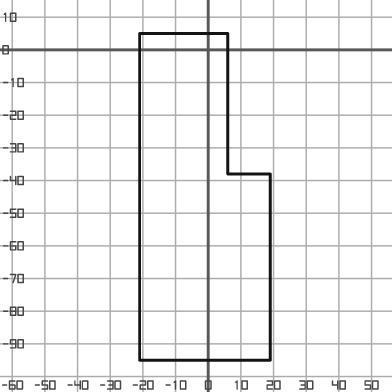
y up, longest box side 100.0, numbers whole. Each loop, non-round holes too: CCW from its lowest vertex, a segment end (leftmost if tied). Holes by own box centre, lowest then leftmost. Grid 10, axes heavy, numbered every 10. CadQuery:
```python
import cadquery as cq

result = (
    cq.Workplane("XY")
    .moveTo(-21.0, -95.0)
    .lineTo(19.0, -95.0)
    .lineTo(19.0, -38.0)
    .lineTo(6.0, -38.0)
    .lineTo(6.0, 5.0)
    .lineTo(-21.0, 5.0)
    .close()
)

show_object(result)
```